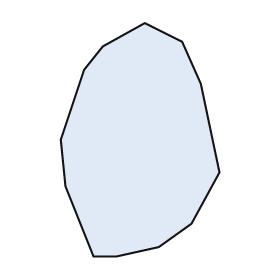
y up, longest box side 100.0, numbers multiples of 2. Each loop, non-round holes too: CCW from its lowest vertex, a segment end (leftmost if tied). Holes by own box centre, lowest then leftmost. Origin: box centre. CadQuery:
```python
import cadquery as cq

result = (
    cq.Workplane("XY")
    .moveTo(-20.0, -50.0)
    .lineTo(-10.0, -50.0)
    .lineTo(8.0, -46.0)
    .lineTo(22.0, -36.0)
    .lineTo(34.0, -14.0)
    .lineTo(26.0, 24.0)
    .lineTo(18.0, 42.0)
    .lineTo(2.0, 50.0)
    .lineTo(-16.0, 40.0)
    .lineTo(-24.0, 30.0)
    .lineTo(-34.0, 0.0)
    .lineTo(-32.0, -20.0)
    .close()
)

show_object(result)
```